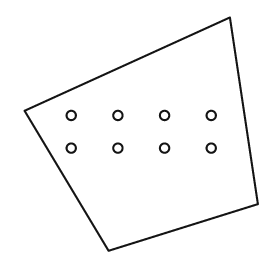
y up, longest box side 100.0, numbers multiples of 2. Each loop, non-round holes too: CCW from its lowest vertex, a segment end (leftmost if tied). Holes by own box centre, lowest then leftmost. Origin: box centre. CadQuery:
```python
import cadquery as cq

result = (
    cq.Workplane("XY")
    .moveTo(-14.0, -50.0)
    .lineTo(50.0, -30.0)
    .lineTo(38.0, 50.0)
    .lineTo(-50.0, 10.0)
    .close()
    .moveTo(-30.0, -6.0)
    .circle(2.0)
    .moveTo(-10.0, -6.0)
    .circle(2.0)
    .moveTo(10.0, -6.0)
    .circle(2.0)
    .moveTo(30.0, -6.0)
    .circle(2.0)
    .moveTo(-30.0, 8.0)
    .circle(2.0)
    .moveTo(-10.0, 8.0)
    .circle(2.0)
    .moveTo(10.0, 8.0)
    .circle(2.0)
    .moveTo(30.0, 8.0)
    .circle(2.0)
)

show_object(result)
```